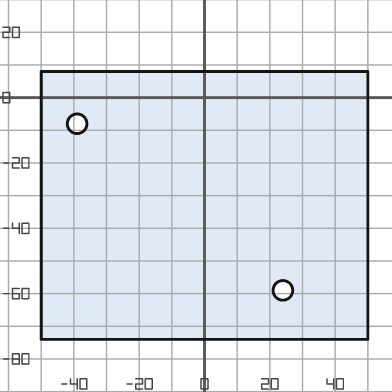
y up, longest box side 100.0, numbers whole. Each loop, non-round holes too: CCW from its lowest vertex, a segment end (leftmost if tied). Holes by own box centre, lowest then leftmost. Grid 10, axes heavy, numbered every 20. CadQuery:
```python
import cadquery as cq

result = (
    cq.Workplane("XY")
    .moveTo(-50.0, -74.0)
    .lineTo(50.0, -74.0)
    .lineTo(50.0, 8.0)
    .lineTo(-50.0, 8.0)
    .close()
    .moveTo(24.0, -59.0)
    .circle(3.0)
    .moveTo(-39.0, -8.0)
    .circle(3.0)
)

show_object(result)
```